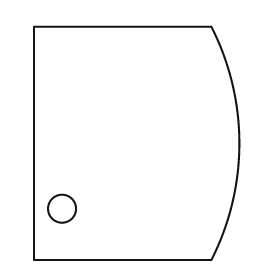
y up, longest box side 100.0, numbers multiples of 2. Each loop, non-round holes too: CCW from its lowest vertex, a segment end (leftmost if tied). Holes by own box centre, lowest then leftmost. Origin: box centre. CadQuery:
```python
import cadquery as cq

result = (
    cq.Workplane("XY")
    .moveTo(-44.0, -50.0)
    .lineTo(32.0, -50.0)
    .threePointArc((44.0, 0.0), (32.0, 50.0))
    .lineTo(-44.0, 50.0)
    .close()
    .moveTo(-32.0, -28.0)
    .circle(6.0)
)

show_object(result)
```